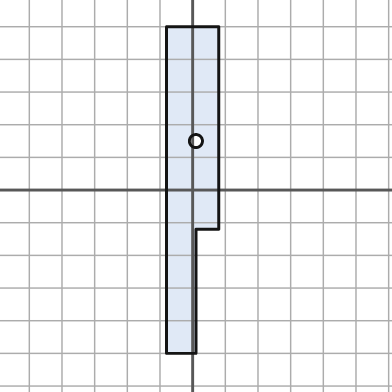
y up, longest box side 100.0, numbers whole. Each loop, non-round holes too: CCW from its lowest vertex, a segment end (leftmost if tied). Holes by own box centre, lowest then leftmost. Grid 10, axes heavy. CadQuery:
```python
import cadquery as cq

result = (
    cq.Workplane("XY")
    .moveTo(-8.0, -50.0)
    .lineTo(1.0, -50.0)
    .lineTo(1.0, -12.0)
    .lineTo(8.0, -12.0)
    .lineTo(8.0, 50.0)
    .lineTo(-8.0, 50.0)
    .close()
    .moveTo(1.0, 15.0)
    .circle(2.0)
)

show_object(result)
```